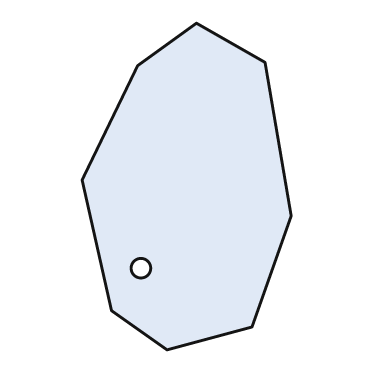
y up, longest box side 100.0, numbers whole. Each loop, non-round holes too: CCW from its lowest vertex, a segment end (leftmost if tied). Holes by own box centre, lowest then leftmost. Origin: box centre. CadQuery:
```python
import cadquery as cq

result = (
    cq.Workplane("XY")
    .moveTo(-6.0, -50.0)
    .lineTo(20.0, -43.0)
    .lineTo(32.0, -9.0)
    .lineTo(24.0, 38.0)
    .lineTo(3.0, 50.0)
    .lineTo(-15.0, 37.0)
    .lineTo(-32.0, 2.0)
    .lineTo(-23.0, -38.0)
    .close()
    .moveTo(-14.0, -25.0)
    .circle(3.0)
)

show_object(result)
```